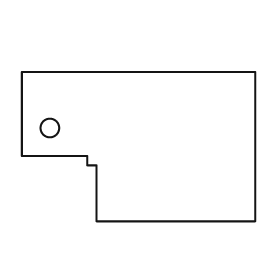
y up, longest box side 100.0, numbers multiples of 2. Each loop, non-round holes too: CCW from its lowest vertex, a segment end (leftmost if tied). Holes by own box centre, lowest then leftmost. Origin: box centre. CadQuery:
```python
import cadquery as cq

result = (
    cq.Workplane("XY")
    .moveTo(-18.0, -32.0)
    .lineTo(50.0, -32.0)
    .lineTo(50.0, 32.0)
    .lineTo(-50.0, 32.0)
    .lineTo(-50.0, -4.0)
    .lineTo(-22.0, -4.0)
    .lineTo(-22.0, -8.0)
    .lineTo(-18.0, -8.0)
    .close()
    .moveTo(-38.0, 8.0)
    .circle(4.0)
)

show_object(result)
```